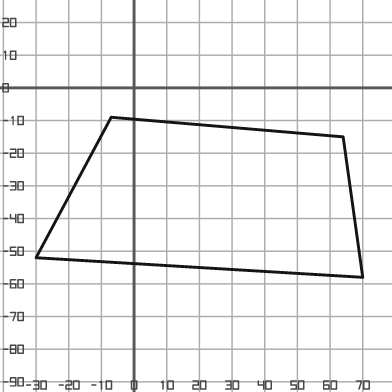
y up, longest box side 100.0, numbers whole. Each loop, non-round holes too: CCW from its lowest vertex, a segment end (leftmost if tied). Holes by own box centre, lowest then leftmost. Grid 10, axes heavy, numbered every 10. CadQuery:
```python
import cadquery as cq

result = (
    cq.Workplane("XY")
    .moveTo(70.0, -58.0)
    .lineTo(64.0, -15.0)
    .lineTo(-7.0, -9.0)
    .lineTo(-30.0, -52.0)
    .close()
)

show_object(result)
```